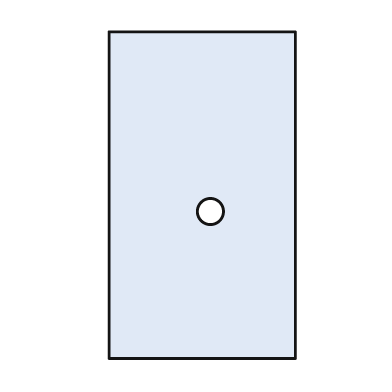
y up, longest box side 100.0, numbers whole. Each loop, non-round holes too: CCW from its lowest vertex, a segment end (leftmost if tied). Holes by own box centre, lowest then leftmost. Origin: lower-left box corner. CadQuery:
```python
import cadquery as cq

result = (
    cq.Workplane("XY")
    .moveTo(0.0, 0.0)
    .lineTo(57.0, 0.0)
    .lineTo(57.0, 100.0)
    .lineTo(0.0, 100.0)
    .close()
    .moveTo(31.0, 45.0)
    .circle(4.0)
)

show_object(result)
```